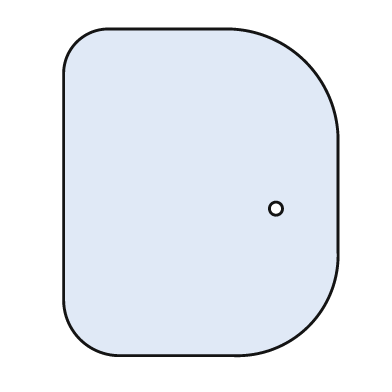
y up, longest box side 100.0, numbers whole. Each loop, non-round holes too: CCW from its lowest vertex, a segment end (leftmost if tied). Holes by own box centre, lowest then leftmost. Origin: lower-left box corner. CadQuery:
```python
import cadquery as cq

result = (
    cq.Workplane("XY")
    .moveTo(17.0, 0.0)
    .lineTo(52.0, 0.0)
    .threePointArc((75.0, 9.0), (84.0, 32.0))
    .lineTo(84.0, 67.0)
    .threePointArc((74.0, 90.0), (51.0, 100.0))
    .lineTo(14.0, 100.0)
    .threePointArc((4.0, 96.0), (0.0, 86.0))
    .lineTo(0.0, 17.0)
    .threePointArc((5.0, 5.0), (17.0, 0.0))
    .close()
    .moveTo(65.0, 45.0)
    .circle(2.0)
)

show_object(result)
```